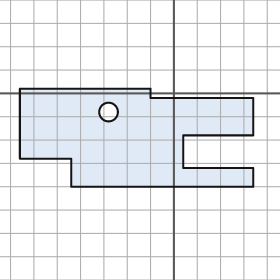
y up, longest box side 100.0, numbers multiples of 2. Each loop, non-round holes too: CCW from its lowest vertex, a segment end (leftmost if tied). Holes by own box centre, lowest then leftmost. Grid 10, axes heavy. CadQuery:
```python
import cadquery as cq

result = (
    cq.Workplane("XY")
    .moveTo(-44.0, -40.0)
    .lineTo(34.0, -40.0)
    .lineTo(34.0, -32.0)
    .lineTo(4.0, -32.0)
    .lineTo(4.0, -18.0)
    .lineTo(34.0, -18.0)
    .lineTo(34.0, -2.0)
    .lineTo(-10.0, -2.0)
    .lineTo(-10.0, 2.0)
    .lineTo(-66.0, 2.0)
    .lineTo(-66.0, -28.0)
    .lineTo(-44.0, -28.0)
    .close()
    .moveTo(-28.0, -8.0)
    .circle(4.0)
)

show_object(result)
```